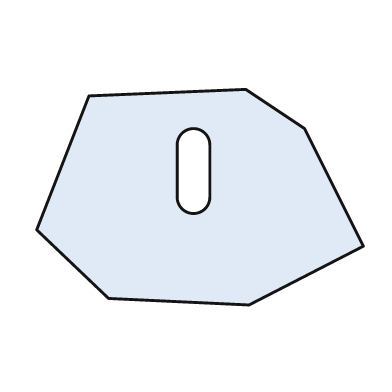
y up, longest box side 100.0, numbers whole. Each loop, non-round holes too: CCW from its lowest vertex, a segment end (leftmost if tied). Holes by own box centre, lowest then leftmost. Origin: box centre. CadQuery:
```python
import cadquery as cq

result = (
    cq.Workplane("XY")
    .moveTo(15.0, -33.0)
    .lineTo(50.0, -15.0)
    .lineTo(32.0, 21.0)
    .lineTo(14.0, 33.0)
    .lineTo(-34.0, 31.0)
    .lineTo(-50.0, -10.0)
    .lineTo(-28.0, -31.0)
    .close()
    .moveTo(-7.0, 0.0)
    .threePointArc((-2.0, -5.0), (3.0, 0.0))
    .lineTo(3.0, 16.0)
    .threePointArc((-2.0, 21.0), (-7.0, 16.0))
    .close()
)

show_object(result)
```